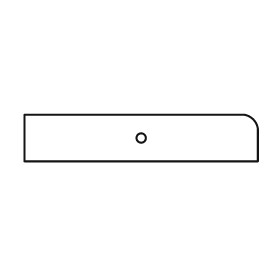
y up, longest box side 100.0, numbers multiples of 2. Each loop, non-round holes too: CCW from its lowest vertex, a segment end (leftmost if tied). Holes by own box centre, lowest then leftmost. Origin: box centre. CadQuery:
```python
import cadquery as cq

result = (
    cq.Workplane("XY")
    .moveTo(-50.0, -10.0)
    .lineTo(50.0, -10.0)
    .lineTo(50.0, 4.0)
    .threePointArc((48.0, 8.0), (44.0, 10.0))
    .lineTo(-50.0, 10.0)
    .close()
    .moveTo(0.0, 0.0)
    .circle(2.0)
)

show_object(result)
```